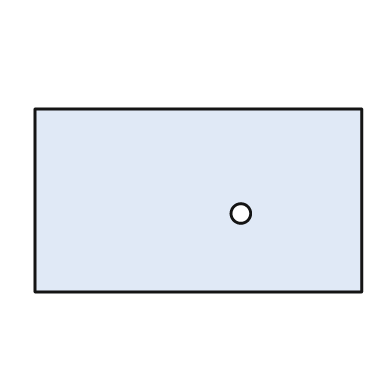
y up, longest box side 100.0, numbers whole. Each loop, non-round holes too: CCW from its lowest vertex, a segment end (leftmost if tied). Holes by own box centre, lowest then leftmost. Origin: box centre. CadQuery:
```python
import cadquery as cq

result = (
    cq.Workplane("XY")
    .moveTo(-50.0, -28.0)
    .lineTo(50.0, -28.0)
    .lineTo(50.0, 28.0)
    .lineTo(-50.0, 28.0)
    .close()
    .moveTo(13.0, -4.0)
    .circle(3.0)
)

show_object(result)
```